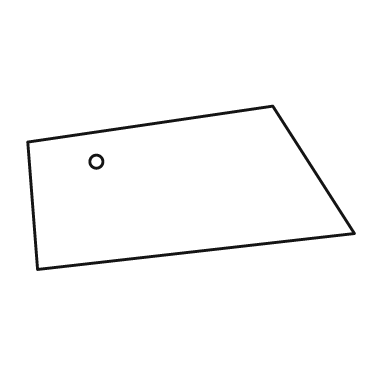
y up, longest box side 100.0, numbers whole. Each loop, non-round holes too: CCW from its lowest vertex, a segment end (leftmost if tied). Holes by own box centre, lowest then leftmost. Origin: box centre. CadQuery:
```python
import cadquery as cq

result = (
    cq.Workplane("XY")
    .moveTo(-47.0, -25.0)
    .lineTo(50.0, -14.0)
    .lineTo(25.0, 25.0)
    .lineTo(-50.0, 14.0)
    .close()
    .moveTo(-29.0, 8.0)
    .circle(2.0)
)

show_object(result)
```